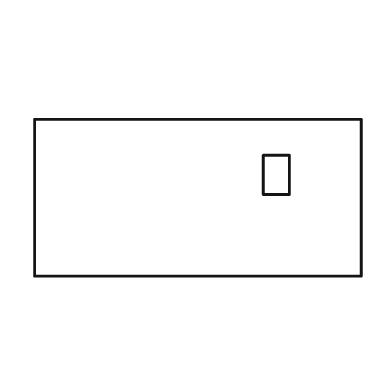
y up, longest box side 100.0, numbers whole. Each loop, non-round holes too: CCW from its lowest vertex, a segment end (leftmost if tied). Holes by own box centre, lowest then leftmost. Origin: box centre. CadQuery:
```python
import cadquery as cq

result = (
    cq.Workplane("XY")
    .moveTo(-50.0, -24.0)
    .lineTo(50.0, -24.0)
    .lineTo(50.0, 24.0)
    .lineTo(-50.0, 24.0)
    .close()
    .moveTo(20.0, 1.0)
    .lineTo(28.0, 1.0)
    .lineTo(28.0, 13.0)
    .lineTo(20.0, 13.0)
    .close()
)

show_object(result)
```